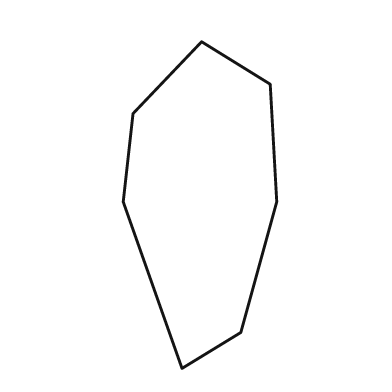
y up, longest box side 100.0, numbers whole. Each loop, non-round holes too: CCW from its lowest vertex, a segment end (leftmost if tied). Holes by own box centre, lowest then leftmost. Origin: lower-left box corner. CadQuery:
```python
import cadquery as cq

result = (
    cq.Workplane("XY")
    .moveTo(18.0, 0.0)
    .lineTo(36.0, 11.0)
    .lineTo(47.0, 51.0)
    .lineTo(45.0, 87.0)
    .lineTo(24.0, 100.0)
    .lineTo(3.0, 78.0)
    .lineTo(0.0, 51.0)
    .close()
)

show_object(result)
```